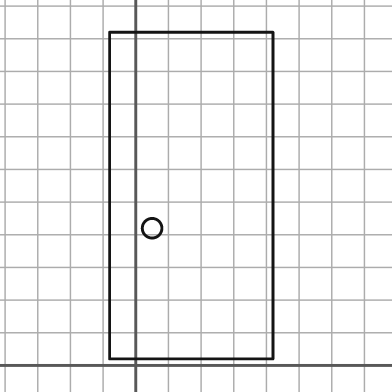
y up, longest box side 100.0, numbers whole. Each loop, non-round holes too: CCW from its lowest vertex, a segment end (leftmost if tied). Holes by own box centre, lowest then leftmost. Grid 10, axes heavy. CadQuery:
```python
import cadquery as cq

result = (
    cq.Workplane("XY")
    .moveTo(-8.0, 2.0)
    .lineTo(42.0, 2.0)
    .lineTo(42.0, 102.0)
    .lineTo(-8.0, 102.0)
    .close()
    .moveTo(5.0, 42.0)
    .circle(3.0)
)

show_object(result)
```